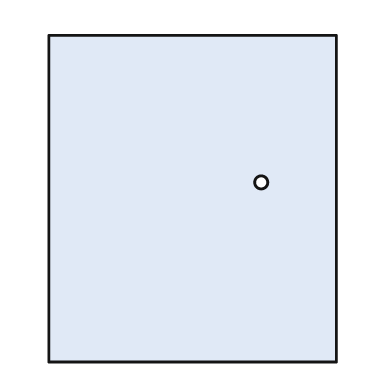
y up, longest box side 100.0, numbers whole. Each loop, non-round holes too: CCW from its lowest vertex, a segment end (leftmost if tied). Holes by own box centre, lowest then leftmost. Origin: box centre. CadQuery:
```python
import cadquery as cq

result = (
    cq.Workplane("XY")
    .moveTo(-44.0, -50.0)
    .lineTo(44.0, -50.0)
    .lineTo(44.0, 50.0)
    .lineTo(-44.0, 50.0)
    .close()
    .moveTo(21.0, 5.0)
    .circle(2.0)
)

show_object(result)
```